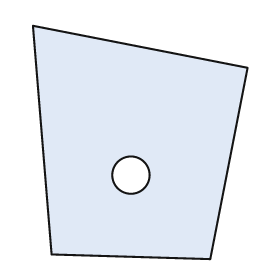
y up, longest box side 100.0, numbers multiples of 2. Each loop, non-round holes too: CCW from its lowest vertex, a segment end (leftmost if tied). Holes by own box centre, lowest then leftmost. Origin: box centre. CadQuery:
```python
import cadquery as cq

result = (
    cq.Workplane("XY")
    .moveTo(30.0, -50.0)
    .lineTo(46.0, 32.0)
    .lineTo(-46.0, 50.0)
    .lineTo(-38.0, -48.0)
    .close()
    .moveTo(-4.0, -14.0)
    .circle(8.0)
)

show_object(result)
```